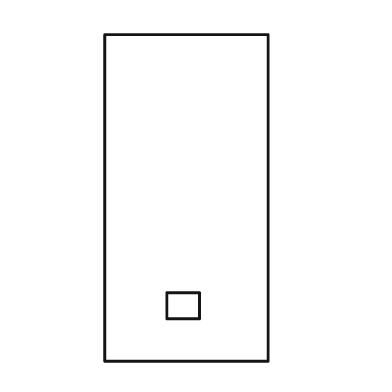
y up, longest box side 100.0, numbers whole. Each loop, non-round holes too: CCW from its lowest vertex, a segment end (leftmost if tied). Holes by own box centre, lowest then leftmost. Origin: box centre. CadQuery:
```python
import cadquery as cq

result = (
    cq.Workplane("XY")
    .moveTo(-25.0, -50.0)
    .lineTo(25.0, -50.0)
    .lineTo(25.0, 50.0)
    .lineTo(-25.0, 50.0)
    .close()
    .moveTo(-6.0, -37.0)
    .lineTo(4.0, -37.0)
    .lineTo(4.0, -29.0)
    .lineTo(-6.0, -29.0)
    .close()
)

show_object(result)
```